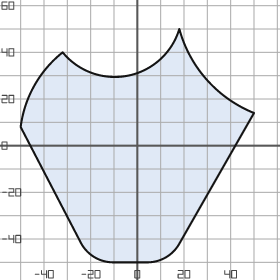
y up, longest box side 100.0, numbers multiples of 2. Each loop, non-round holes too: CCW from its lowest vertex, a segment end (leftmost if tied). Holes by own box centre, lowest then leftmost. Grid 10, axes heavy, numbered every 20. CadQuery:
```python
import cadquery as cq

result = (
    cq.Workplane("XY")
    .moveTo(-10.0, -50.0)
    .lineTo(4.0, -50.0)
    .threePointArc((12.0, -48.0), (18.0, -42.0))
    .lineTo(50.0, 14.0)
    .threePointArc((30.0, 28.0), (18.0, 50.0))
    .threePointArc((-4.0, 30.0), (-32.0, 40.0))
    .threePointArc((-44.0, 26.0), (-50.0, 8.0))
    .lineTo(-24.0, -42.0)
    .threePointArc((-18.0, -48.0), (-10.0, -50.0))
    .close()
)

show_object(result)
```